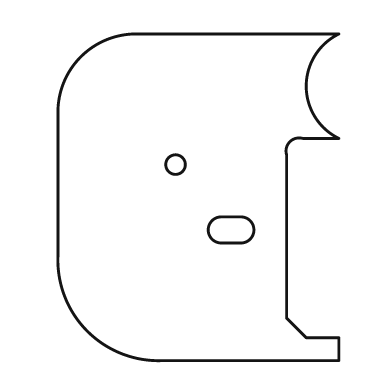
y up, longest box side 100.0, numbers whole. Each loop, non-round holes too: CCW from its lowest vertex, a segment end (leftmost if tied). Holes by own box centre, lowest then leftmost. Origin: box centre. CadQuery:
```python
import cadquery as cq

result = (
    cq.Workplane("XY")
    .moveTo(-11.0, -50.0)
    .lineTo(43.0, -50.0)
    .lineTo(43.0, -43.0)
    .lineTo(33.0, -43.0)
    .lineTo(27.0, -37.0)
    .lineTo(27.0, 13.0)
    .threePointArc((28.0, 17.0), (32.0, 18.0))
    .lineTo(43.0, 18.0)
    .threePointArc((33.0, 34.0), (43.0, 50.0))
    .lineTo(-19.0, 50.0)
    .threePointArc((-36.0, 43.0), (-43.0, 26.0))
    .lineTo(-43.0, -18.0)
    .threePointArc((-34.0, -41.0), (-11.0, -50.0))
    .close()
    .moveTo(7.0, -14.0)
    .lineTo(13.0, -14.0)
    .threePointArc((17.0, -10.0), (13.0, -6.0))
    .lineTo(7.0, -6.0)
    .threePointArc((3.0, -10.0), (7.0, -14.0))
    .close()
    .moveTo(-7.0, 10.0)
    .circle(3.0)
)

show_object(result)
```